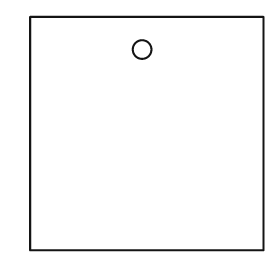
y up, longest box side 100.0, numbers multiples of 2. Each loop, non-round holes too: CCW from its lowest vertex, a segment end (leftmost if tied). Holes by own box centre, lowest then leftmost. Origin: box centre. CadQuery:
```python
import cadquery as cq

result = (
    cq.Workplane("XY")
    .moveTo(-50.0, -50.0)
    .lineTo(50.0, -50.0)
    .lineTo(50.0, 50.0)
    .lineTo(-50.0, 50.0)
    .close()
    .moveTo(-2.0, 36.0)
    .circle(4.0)
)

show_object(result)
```